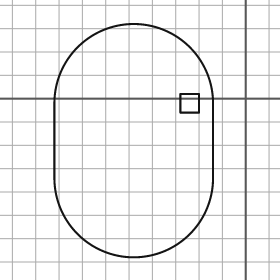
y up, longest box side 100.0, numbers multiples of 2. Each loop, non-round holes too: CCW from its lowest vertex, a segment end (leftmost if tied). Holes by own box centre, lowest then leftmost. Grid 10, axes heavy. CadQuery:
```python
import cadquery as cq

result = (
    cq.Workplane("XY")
    .moveTo(-82.0, -34.0)
    .threePointArc((-48.0, -68.0), (-14.0, -34.0))
    .lineTo(-14.0, -2.0)
    .threePointArc((-48.0, 32.0), (-82.0, -2.0))
    .close()
    .moveTo(-28.0, -6.0)
    .lineTo(-20.0, -6.0)
    .lineTo(-20.0, 2.0)
    .lineTo(-28.0, 2.0)
    .close()
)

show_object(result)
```